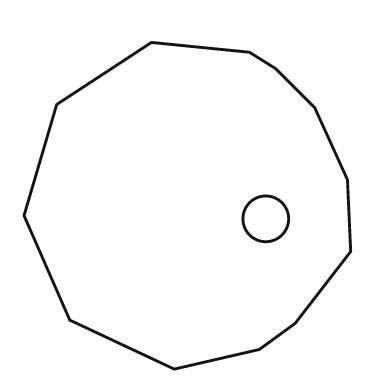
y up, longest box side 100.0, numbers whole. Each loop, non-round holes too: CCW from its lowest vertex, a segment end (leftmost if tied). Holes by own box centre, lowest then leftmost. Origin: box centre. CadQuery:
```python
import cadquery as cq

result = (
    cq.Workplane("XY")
    .moveTo(-4.0, -50.0)
    .lineTo(22.0, -44.0)
    .lineTo(33.0, -36.0)
    .lineTo(50.0, -14.0)
    .lineTo(49.0, 8.0)
    .lineTo(39.0, 30.0)
    .lineTo(27.0, 42.0)
    .lineTo(19.0, 47.0)
    .lineTo(-11.0, 50.0)
    .lineTo(-40.0, 31.0)
    .lineTo(-50.0, -3.0)
    .lineTo(-36.0, -35.0)
    .close()
    .moveTo(24.0, -4.0)
    .circle(7.0)
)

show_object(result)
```